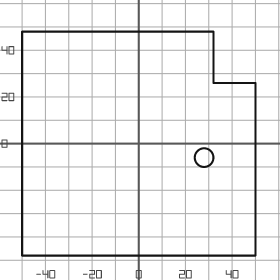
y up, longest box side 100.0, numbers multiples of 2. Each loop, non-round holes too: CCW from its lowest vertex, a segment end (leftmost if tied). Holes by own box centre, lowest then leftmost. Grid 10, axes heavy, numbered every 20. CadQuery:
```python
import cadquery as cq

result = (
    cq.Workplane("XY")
    .moveTo(-50.0, -48.0)
    .lineTo(50.0, -48.0)
    .lineTo(50.0, 26.0)
    .lineTo(32.0, 26.0)
    .lineTo(32.0, 48.0)
    .lineTo(-50.0, 48.0)
    .close()
    .moveTo(28.0, -6.0)
    .circle(4.0)
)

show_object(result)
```